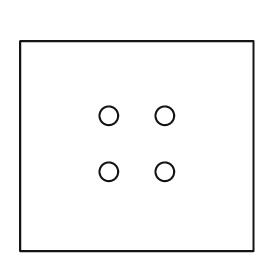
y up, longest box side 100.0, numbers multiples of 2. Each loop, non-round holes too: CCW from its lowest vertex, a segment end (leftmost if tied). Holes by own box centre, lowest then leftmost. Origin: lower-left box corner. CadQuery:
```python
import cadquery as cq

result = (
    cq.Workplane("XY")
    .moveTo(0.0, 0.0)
    .lineTo(100.0, 0.0)
    .lineTo(100.0, 90.0)
    .lineTo(0.0, 90.0)
    .close()
    .moveTo(38.0, 34.0)
    .circle(4.0)
    .moveTo(62.0, 34.0)
    .circle(4.0)
    .moveTo(38.0, 58.0)
    .circle(4.0)
    .moveTo(62.0, 58.0)
    .circle(4.0)
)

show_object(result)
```